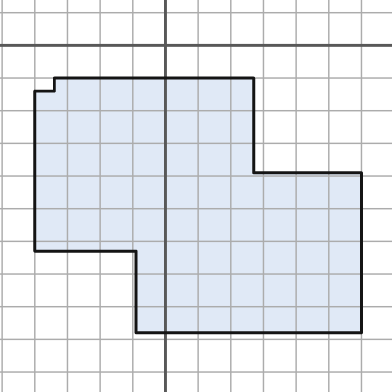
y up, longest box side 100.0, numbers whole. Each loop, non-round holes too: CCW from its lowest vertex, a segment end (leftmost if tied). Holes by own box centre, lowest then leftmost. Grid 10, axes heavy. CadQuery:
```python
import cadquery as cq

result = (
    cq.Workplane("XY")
    .moveTo(-9.0, -88.0)
    .lineTo(60.0, -88.0)
    .lineTo(60.0, -39.0)
    .lineTo(27.0, -39.0)
    .lineTo(27.0, -10.0)
    .lineTo(-34.0, -10.0)
    .lineTo(-34.0, -14.0)
    .lineTo(-40.0, -14.0)
    .lineTo(-40.0, -63.0)
    .lineTo(-9.0, -63.0)
    .close()
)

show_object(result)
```